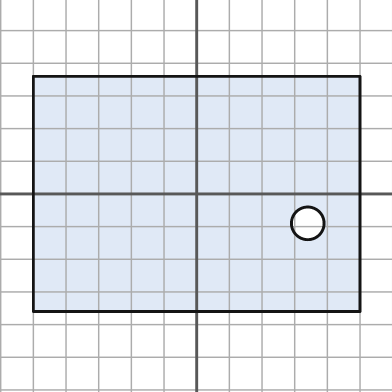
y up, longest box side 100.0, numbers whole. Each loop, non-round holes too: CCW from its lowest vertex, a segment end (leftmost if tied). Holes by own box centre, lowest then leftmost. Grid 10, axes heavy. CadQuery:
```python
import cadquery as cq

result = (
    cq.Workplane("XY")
    .moveTo(-50.0, -36.0)
    .lineTo(50.0, -36.0)
    .lineTo(50.0, 36.0)
    .lineTo(-50.0, 36.0)
    .close()
    .moveTo(34.0, -9.0)
    .circle(5.0)
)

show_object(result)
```